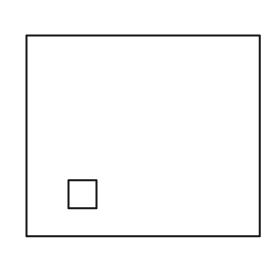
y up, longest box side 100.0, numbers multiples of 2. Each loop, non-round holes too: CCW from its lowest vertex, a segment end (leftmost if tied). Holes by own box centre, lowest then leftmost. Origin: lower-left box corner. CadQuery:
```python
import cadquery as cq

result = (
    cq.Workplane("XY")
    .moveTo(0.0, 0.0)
    .lineTo(100.0, 0.0)
    .lineTo(100.0, 86.0)
    .lineTo(0.0, 86.0)
    .close()
    .moveTo(18.0, 12.0)
    .lineTo(30.0, 12.0)
    .lineTo(30.0, 24.0)
    .lineTo(18.0, 24.0)
    .close()
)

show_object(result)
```